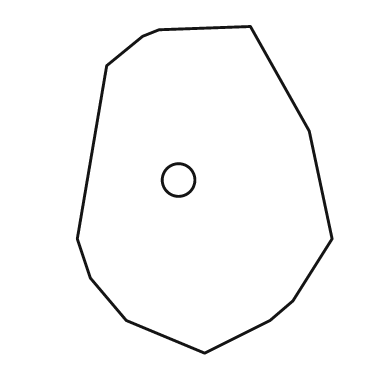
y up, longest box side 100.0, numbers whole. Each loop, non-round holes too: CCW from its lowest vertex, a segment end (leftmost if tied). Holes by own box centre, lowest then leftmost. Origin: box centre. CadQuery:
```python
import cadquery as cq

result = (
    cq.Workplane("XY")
    .moveTo(0.0, -50.0)
    .lineTo(20.0, -40.0)
    .lineTo(27.0, -34.0)
    .lineTo(39.0, -15.0)
    .lineTo(32.0, 18.0)
    .lineTo(14.0, 50.0)
    .lineTo(-14.0, 49.0)
    .lineTo(-19.0, 47.0)
    .lineTo(-30.0, 38.0)
    .lineTo(-39.0, -15.0)
    .lineTo(-35.0, -27.0)
    .lineTo(-24.0, -40.0)
    .close()
    .moveTo(-8.0, 3.0)
    .circle(5.0)
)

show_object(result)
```